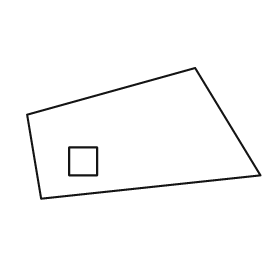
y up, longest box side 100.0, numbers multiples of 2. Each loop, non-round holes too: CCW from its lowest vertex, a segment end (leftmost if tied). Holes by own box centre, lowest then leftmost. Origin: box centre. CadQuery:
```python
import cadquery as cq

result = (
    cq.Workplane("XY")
    .moveTo(-44.0, -28.0)
    .lineTo(50.0, -18.0)
    .lineTo(22.0, 28.0)
    .lineTo(-50.0, 8.0)
    .close()
    .moveTo(-32.0, -18.0)
    .lineTo(-20.0, -18.0)
    .lineTo(-20.0, -6.0)
    .lineTo(-32.0, -6.0)
    .close()
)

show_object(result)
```